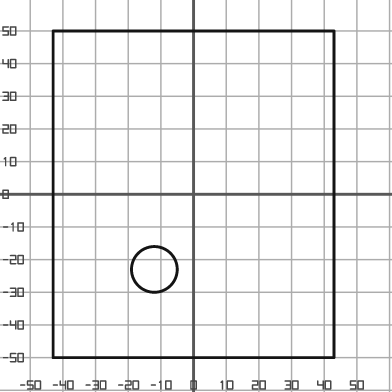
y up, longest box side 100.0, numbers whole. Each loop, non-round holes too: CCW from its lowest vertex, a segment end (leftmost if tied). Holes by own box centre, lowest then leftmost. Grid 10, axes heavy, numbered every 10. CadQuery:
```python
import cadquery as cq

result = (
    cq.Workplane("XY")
    .moveTo(-43.0, -50.0)
    .lineTo(43.0, -50.0)
    .lineTo(43.0, 50.0)
    .lineTo(-43.0, 50.0)
    .close()
    .moveTo(-12.0, -23.0)
    .circle(7.0)
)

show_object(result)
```